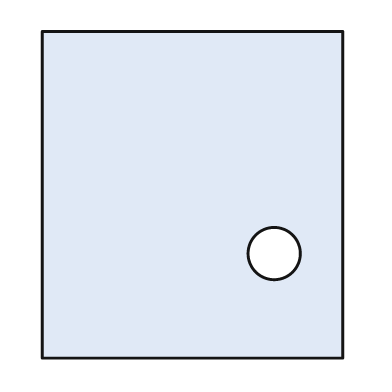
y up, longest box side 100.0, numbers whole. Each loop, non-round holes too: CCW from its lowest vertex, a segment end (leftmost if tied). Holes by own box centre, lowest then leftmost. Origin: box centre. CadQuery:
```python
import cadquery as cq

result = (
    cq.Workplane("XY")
    .moveTo(-46.0, -50.0)
    .lineTo(46.0, -50.0)
    .lineTo(46.0, 50.0)
    .lineTo(-46.0, 50.0)
    .close()
    .moveTo(25.0, -18.0)
    .circle(8.0)
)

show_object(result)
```